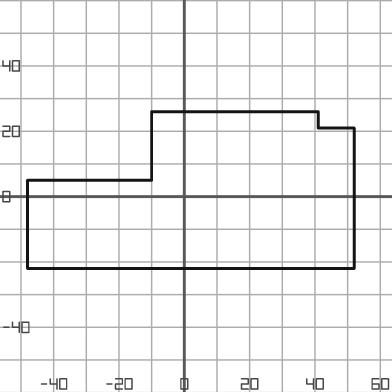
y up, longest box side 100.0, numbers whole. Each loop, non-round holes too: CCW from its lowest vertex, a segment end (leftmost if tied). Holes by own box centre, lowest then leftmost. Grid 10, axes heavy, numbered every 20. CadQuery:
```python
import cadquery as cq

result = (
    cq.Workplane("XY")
    .moveTo(-48.0, -22.0)
    .lineTo(52.0, -22.0)
    .lineTo(52.0, 21.0)
    .lineTo(41.0, 21.0)
    .lineTo(41.0, 26.0)
    .lineTo(-10.0, 26.0)
    .lineTo(-10.0, 5.0)
    .lineTo(-48.0, 5.0)
    .close()
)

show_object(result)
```